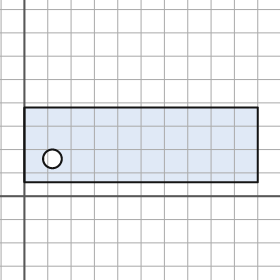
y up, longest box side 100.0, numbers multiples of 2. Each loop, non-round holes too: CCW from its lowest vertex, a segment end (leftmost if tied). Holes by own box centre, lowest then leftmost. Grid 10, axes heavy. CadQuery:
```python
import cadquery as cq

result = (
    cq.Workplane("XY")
    .moveTo(0.0, 6.0)
    .lineTo(100.0, 6.0)
    .lineTo(100.0, 38.0)
    .lineTo(0.0, 38.0)
    .close()
    .moveTo(12.0, 16.0)
    .circle(4.0)
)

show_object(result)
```